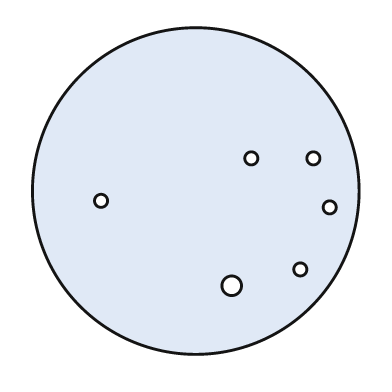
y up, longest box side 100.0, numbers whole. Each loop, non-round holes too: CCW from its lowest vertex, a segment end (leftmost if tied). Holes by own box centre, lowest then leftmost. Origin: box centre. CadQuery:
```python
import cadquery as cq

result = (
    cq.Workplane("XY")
    .moveTo(0.0, 0.0)
    .circle(50.0)
    .moveTo(11.0, -29.0)
    .circle(3.0)
    .moveTo(32.0, -24.0)
    .circle(2.0)
    .moveTo(41.0, -5.0)
    .circle(2.0)
    .moveTo(-29.0, -3.0)
    .circle(2.0)
    .moveTo(17.0, 10.0)
    .circle(2.0)
    .moveTo(36.0, 10.0)
    .circle(2.0)
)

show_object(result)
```